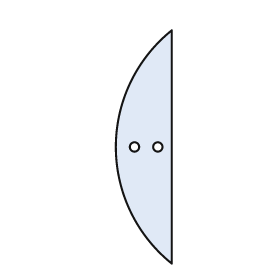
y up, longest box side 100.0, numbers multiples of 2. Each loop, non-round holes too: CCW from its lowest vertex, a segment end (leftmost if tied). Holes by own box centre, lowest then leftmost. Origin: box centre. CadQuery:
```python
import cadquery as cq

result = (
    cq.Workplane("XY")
    .moveTo(12.0, -50.0)
    .lineTo(12.0, 50.0)
    .threePointArc((-12.0, 0.0), (12.0, -50.0))
    .close()
    .moveTo(-4.0, 0.0)
    .circle(2.0)
    .moveTo(6.0, 0.0)
    .circle(2.0)
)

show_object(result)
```